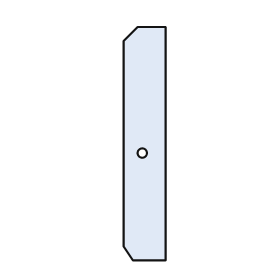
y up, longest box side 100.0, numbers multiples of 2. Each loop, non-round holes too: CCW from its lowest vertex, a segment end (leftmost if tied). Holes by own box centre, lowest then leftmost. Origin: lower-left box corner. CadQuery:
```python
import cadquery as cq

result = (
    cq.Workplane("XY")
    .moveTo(4.0, 0.0)
    .lineTo(18.0, 0.0)
    .lineTo(18.0, 100.0)
    .lineTo(6.0, 100.0)
    .lineTo(0.0, 94.0)
    .lineTo(0.0, 6.0)
    .close()
    .moveTo(8.0, 46.0)
    .circle(2.0)
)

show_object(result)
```